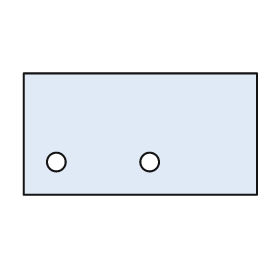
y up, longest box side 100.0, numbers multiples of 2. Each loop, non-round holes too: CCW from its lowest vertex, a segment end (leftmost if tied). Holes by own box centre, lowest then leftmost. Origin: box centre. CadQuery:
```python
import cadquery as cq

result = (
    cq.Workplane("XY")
    .moveTo(-50.0, -26.0)
    .lineTo(50.0, -26.0)
    .lineTo(50.0, 26.0)
    .lineTo(-50.0, 26.0)
    .close()
    .moveTo(-36.0, -12.0)
    .circle(4.0)
    .moveTo(4.0, -12.0)
    .circle(4.0)
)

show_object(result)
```